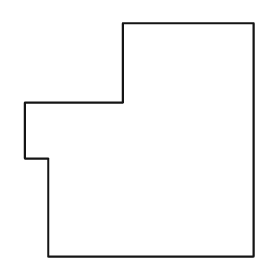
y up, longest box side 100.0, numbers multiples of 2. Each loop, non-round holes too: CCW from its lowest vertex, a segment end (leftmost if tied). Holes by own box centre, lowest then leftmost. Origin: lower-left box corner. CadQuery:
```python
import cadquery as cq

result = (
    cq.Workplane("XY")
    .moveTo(10.0, 0.0)
    .lineTo(98.0, 0.0)
    .lineTo(98.0, 100.0)
    .lineTo(42.0, 100.0)
    .lineTo(42.0, 66.0)
    .lineTo(0.0, 66.0)
    .lineTo(0.0, 42.0)
    .lineTo(10.0, 42.0)
    .close()
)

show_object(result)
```